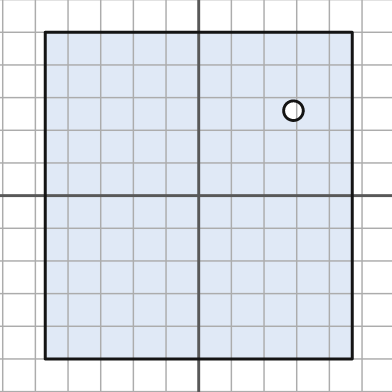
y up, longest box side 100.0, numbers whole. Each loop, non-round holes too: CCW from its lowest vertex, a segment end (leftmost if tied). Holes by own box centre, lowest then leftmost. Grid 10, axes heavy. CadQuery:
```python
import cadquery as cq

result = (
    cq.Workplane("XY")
    .moveTo(-47.0, -50.0)
    .lineTo(47.0, -50.0)
    .lineTo(47.0, 50.0)
    .lineTo(-47.0, 50.0)
    .close()
    .moveTo(29.0, 26.0)
    .circle(3.0)
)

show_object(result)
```